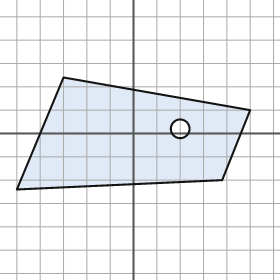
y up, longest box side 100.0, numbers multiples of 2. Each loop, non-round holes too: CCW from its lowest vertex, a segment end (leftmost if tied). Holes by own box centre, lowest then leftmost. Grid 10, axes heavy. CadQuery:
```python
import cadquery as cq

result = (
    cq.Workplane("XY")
    .moveTo(-50.0, -24.0)
    .lineTo(38.0, -20.0)
    .lineTo(50.0, 10.0)
    .lineTo(-30.0, 24.0)
    .close()
    .moveTo(20.0, 2.0)
    .circle(4.0)
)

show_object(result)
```